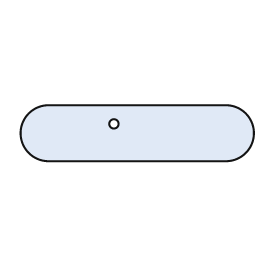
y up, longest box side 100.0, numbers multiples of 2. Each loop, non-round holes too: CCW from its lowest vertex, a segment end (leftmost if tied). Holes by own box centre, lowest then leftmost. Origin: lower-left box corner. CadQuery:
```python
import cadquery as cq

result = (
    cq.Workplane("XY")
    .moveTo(12.0, 0.0)
    .lineTo(88.0, 0.0)
    .threePointArc((100.0, 12.0), (88.0, 24.0))
    .lineTo(12.0, 24.0)
    .threePointArc((0.0, 12.0), (12.0, 0.0))
    .close()
    .moveTo(40.0, 16.0)
    .circle(2.0)
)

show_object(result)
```